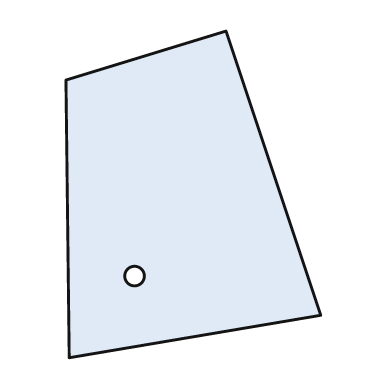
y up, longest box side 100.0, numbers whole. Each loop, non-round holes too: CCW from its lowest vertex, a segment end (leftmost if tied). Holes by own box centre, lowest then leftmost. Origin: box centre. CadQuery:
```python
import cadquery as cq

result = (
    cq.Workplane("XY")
    .moveTo(-38.0, -50.0)
    .lineTo(39.0, -37.0)
    .lineTo(10.0, 50.0)
    .lineTo(-39.0, 35.0)
    .close()
    .moveTo(-18.0, -25.0)
    .circle(3.0)
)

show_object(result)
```